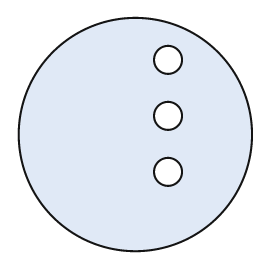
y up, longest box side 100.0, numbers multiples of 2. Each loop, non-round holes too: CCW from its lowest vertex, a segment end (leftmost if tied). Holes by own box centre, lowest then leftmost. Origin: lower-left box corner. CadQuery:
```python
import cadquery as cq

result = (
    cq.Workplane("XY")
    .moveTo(50.0, 50.0)
    .circle(50.0)
    .moveTo(64.0, 34.0)
    .circle(6.0)
    .moveTo(64.0, 58.0)
    .circle(6.0)
    .moveTo(64.0, 82.0)
    .circle(6.0)
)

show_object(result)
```